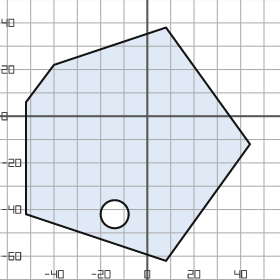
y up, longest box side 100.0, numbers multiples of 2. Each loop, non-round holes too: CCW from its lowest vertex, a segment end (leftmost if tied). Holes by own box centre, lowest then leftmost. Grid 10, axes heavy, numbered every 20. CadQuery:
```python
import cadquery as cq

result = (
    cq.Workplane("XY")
    .moveTo(8.0, -62.0)
    .lineTo(44.0, -12.0)
    .lineTo(8.0, 38.0)
    .lineTo(-40.0, 22.0)
    .lineTo(-52.0, 6.0)
    .lineTo(-52.0, -42.0)
    .close()
    .moveTo(-14.0, -42.0)
    .circle(6.0)
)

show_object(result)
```